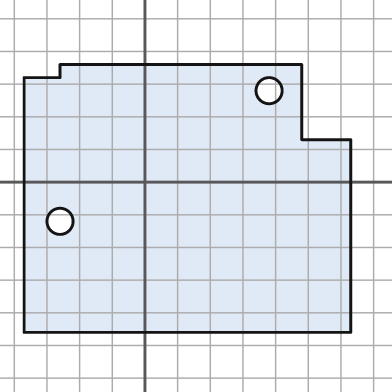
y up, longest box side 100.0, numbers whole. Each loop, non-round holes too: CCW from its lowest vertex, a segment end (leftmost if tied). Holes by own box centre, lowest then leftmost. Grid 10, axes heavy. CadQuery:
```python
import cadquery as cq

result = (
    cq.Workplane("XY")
    .moveTo(-37.0, -46.0)
    .lineTo(63.0, -46.0)
    .lineTo(63.0, 13.0)
    .lineTo(48.0, 13.0)
    .lineTo(48.0, 36.0)
    .lineTo(-26.0, 36.0)
    .lineTo(-26.0, 32.0)
    .lineTo(-37.0, 32.0)
    .close()
    .moveTo(-26.0, -12.0)
    .circle(4.0)
    .moveTo(38.0, 28.0)
    .circle(4.0)
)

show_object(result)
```